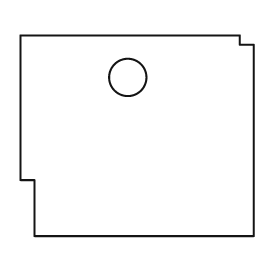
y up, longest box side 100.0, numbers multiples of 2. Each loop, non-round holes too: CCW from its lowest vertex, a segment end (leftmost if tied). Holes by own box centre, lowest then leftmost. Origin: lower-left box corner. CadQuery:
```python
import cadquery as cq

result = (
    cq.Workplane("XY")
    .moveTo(6.0, 0.0)
    .lineTo(100.0, 0.0)
    .lineTo(100.0, 82.0)
    .lineTo(94.0, 82.0)
    .lineTo(94.0, 86.0)
    .lineTo(0.0, 86.0)
    .lineTo(0.0, 24.0)
    .lineTo(6.0, 24.0)
    .close()
    .moveTo(46.0, 68.0)
    .circle(8.0)
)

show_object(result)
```